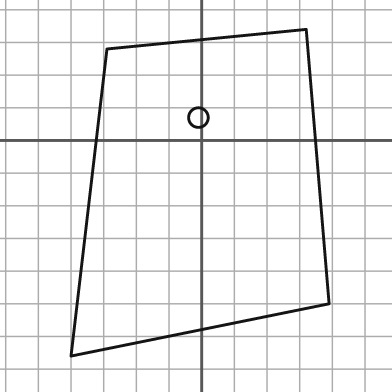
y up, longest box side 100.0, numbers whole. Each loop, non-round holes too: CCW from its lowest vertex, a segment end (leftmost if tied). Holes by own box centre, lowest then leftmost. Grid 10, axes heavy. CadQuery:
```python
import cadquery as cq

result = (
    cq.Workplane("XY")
    .moveTo(-40.0, -66.0)
    .lineTo(39.0, -50.0)
    .lineTo(32.0, 34.0)
    .lineTo(-29.0, 28.0)
    .close()
    .moveTo(-1.0, 7.0)
    .circle(3.0)
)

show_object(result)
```